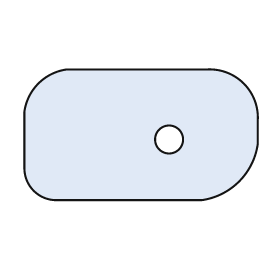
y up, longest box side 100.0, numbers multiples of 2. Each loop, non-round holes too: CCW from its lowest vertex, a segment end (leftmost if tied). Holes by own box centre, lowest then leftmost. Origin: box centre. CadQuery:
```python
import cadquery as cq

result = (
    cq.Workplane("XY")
    .moveTo(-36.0, -28.0)
    .lineTo(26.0, -28.0)
    .threePointArc((42.0, -20.0), (50.0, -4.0))
    .lineTo(50.0, 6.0)
    .threePointArc((44.0, 22.0), (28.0, 28.0))
    .lineTo(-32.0, 28.0)
    .threePointArc((-44.0, 22.0), (-50.0, 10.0))
    .lineTo(-50.0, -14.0)
    .threePointArc((-46.0, -24.0), (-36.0, -28.0))
    .close()
    .moveTo(12.0, -2.0)
    .circle(6.0)
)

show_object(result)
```